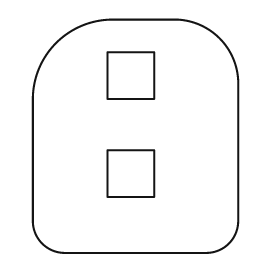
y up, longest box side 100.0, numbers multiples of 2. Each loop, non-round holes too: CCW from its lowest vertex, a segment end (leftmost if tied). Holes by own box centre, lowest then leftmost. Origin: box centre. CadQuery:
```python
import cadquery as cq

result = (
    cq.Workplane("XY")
    .moveTo(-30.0, -50.0)
    .lineTo(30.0, -50.0)
    .threePointArc((40.0, -46.0), (44.0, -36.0))
    .lineTo(44.0, 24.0)
    .threePointArc((36.0, 42.0), (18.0, 50.0))
    .lineTo(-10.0, 50.0)
    .threePointArc((-34.0, 40.0), (-44.0, 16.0))
    .lineTo(-44.0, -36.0)
    .threePointArc((-40.0, -46.0), (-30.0, -50.0))
    .close()
    .moveTo(-12.0, -26.0)
    .lineTo(8.0, -26.0)
    .lineTo(8.0, -6.0)
    .lineTo(-12.0, -6.0)
    .close()
    .moveTo(-12.0, 16.0)
    .lineTo(8.0, 16.0)
    .lineTo(8.0, 36.0)
    .lineTo(-12.0, 36.0)
    .close()
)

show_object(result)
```